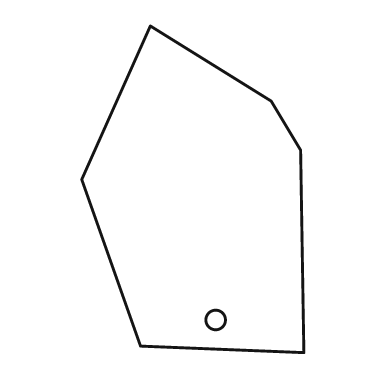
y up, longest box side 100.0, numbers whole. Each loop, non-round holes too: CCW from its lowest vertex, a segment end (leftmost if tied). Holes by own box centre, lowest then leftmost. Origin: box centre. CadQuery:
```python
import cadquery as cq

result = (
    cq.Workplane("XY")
    .moveTo(34.0, -50.0)
    .lineTo(33.0, 12.0)
    .lineTo(24.0, 27.0)
    .lineTo(-13.0, 50.0)
    .lineTo(-34.0, 3.0)
    .lineTo(-16.0, -48.0)
    .close()
    .moveTo(7.0, -40.0)
    .circle(3.0)
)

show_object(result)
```